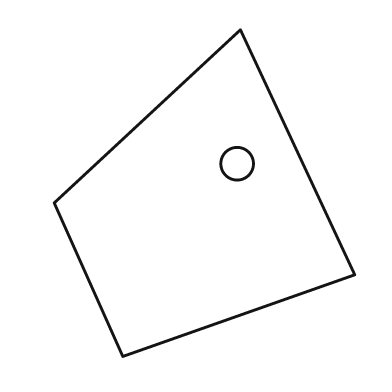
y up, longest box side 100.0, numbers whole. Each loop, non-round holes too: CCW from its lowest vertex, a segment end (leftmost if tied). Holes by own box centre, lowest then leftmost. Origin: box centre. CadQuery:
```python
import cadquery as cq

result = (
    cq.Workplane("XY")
    .moveTo(-25.0, -50.0)
    .lineTo(46.0, -25.0)
    .lineTo(11.0, 50.0)
    .lineTo(-46.0, -3.0)
    .close()
    .moveTo(10.0, 9.0)
    .circle(5.0)
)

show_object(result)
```